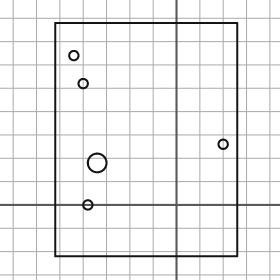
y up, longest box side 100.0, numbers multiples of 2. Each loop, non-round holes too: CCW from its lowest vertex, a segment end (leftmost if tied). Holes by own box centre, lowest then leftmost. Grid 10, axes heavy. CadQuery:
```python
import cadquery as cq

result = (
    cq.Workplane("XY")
    .moveTo(-52.0, -22.0)
    .lineTo(26.0, -22.0)
    .lineTo(26.0, 78.0)
    .lineTo(-52.0, 78.0)
    .close()
    .moveTo(-38.0, 0.0)
    .circle(2.0)
    .moveTo(-34.0, 18.0)
    .circle(4.0)
    .moveTo(20.0, 26.0)
    .circle(2.0)
    .moveTo(-40.0, 52.0)
    .circle(2.0)
    .moveTo(-44.0, 64.0)
    .circle(2.0)
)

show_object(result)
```